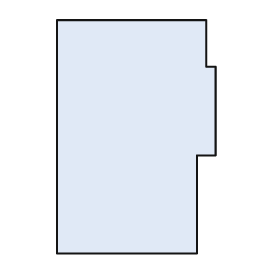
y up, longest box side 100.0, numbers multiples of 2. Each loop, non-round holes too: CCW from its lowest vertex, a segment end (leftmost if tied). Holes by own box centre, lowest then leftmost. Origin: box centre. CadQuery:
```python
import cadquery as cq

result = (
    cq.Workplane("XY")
    .moveTo(-34.0, -50.0)
    .lineTo(26.0, -50.0)
    .lineTo(26.0, -8.0)
    .lineTo(34.0, -8.0)
    .lineTo(34.0, 30.0)
    .lineTo(30.0, 30.0)
    .lineTo(30.0, 50.0)
    .lineTo(-34.0, 50.0)
    .close()
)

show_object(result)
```